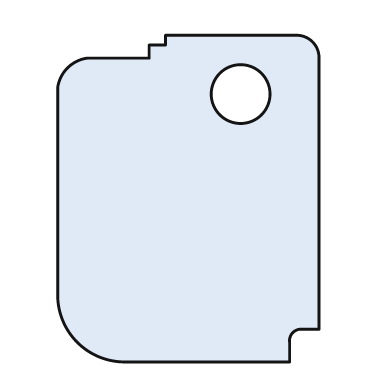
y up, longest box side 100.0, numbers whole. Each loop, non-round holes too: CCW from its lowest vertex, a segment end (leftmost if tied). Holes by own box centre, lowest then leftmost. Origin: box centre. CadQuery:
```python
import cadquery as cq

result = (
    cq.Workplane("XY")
    .moveTo(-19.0, -50.0)
    .lineTo(31.0, -50.0)
    .lineTo(31.0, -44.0)
    .threePointArc((32.0, -41.0), (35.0, -40.0))
    .lineTo(40.0, -40.0)
    .lineTo(40.0, 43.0)
    .threePointArc((38.0, 48.0), (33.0, 50.0))
    .lineTo(-7.0, 50.0)
    .lineTo(-7.0, 47.0)
    .lineTo(-12.0, 47.0)
    .lineTo(-12.0, 43.0)
    .lineTo(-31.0, 43.0)
    .threePointArc((-37.0, 40.0), (-40.0, 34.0))
    .lineTo(-40.0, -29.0)
    .threePointArc((-34.0, -44.0), (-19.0, -50.0))
    .close()
    .moveTo(16.0, 32.0)
    .circle(9.0)
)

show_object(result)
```